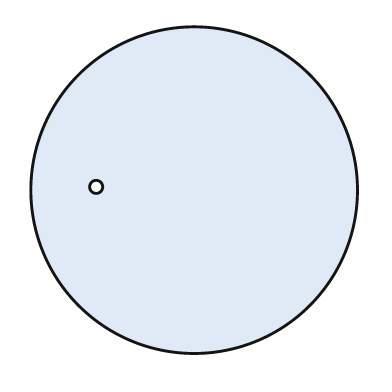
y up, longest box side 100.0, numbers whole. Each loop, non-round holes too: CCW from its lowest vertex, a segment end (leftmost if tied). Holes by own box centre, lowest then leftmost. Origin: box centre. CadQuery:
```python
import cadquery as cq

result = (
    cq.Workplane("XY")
    .moveTo(0.0, 0.0)
    .circle(50.0)
    .moveTo(-30.0, 1.0)
    .circle(2.0)
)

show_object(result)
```